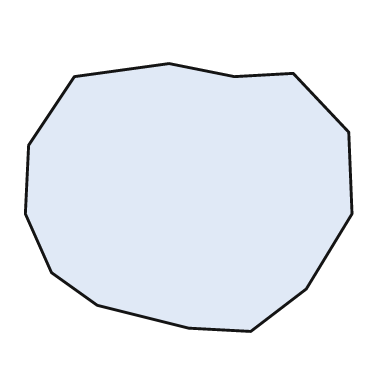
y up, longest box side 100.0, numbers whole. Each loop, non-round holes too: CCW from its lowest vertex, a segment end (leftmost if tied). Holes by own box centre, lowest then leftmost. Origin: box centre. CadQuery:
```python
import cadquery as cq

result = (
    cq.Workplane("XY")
    .moveTo(19.0, -41.0)
    .lineTo(36.0, -28.0)
    .lineTo(50.0, -5.0)
    .lineTo(49.0, 20.0)
    .lineTo(32.0, 38.0)
    .lineTo(14.0, 37.0)
    .lineTo(-6.0, 41.0)
    .lineTo(-35.0, 37.0)
    .lineTo(-49.0, 16.0)
    .lineTo(-50.0, -5.0)
    .lineTo(-42.0, -23.0)
    .lineTo(-28.0, -33.0)
    .lineTo(0.0, -40.0)
    .close()
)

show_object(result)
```